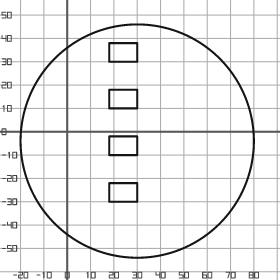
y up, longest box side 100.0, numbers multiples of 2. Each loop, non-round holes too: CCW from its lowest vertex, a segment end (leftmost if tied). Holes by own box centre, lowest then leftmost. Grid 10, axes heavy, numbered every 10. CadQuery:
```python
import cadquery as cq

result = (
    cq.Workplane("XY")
    .moveTo(30.0, -4.0)
    .circle(50.0)
    .moveTo(18.0, -30.0)
    .lineTo(30.0, -30.0)
    .lineTo(30.0, -22.0)
    .lineTo(18.0, -22.0)
    .close()
    .moveTo(18.0, -10.0)
    .lineTo(30.0, -10.0)
    .lineTo(30.0, -2.0)
    .lineTo(18.0, -2.0)
    .close()
    .moveTo(18.0, 10.0)
    .lineTo(30.0, 10.0)
    .lineTo(30.0, 18.0)
    .lineTo(18.0, 18.0)
    .close()
    .moveTo(18.0, 30.0)
    .lineTo(30.0, 30.0)
    .lineTo(30.0, 38.0)
    .lineTo(18.0, 38.0)
    .close()
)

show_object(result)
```